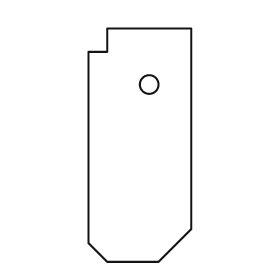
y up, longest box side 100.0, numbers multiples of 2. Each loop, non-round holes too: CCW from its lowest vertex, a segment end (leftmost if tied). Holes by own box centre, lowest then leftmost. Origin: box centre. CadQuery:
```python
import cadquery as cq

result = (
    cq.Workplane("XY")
    .moveTo(-14.0, -50.0)
    .lineTo(8.0, -50.0)
    .lineTo(22.0, -36.0)
    .lineTo(22.0, 50.0)
    .lineTo(-14.0, 50.0)
    .lineTo(-14.0, 40.0)
    .lineTo(-22.0, 40.0)
    .lineTo(-22.0, -42.0)
    .close()
    .moveTo(4.0, 26.0)
    .circle(4.0)
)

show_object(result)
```